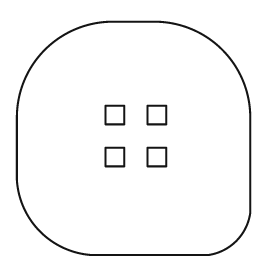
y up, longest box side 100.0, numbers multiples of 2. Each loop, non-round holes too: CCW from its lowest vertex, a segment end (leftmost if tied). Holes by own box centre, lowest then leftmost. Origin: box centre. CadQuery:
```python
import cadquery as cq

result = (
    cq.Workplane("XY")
    .moveTo(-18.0, -50.0)
    .lineTo(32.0, -50.0)
    .threePointArc((44.0, -44.0), (50.0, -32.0))
    .lineTo(50.0, 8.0)
    .threePointArc((38.0, 38.0), (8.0, 50.0))
    .lineTo(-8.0, 50.0)
    .threePointArc((-38.0, 38.0), (-50.0, 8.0))
    .lineTo(-50.0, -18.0)
    .threePointArc((-40.0, -40.0), (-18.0, -50.0))
    .close()
    .moveTo(-12.0, -12.0)
    .lineTo(-4.0, -12.0)
    .lineTo(-4.0, -4.0)
    .lineTo(-12.0, -4.0)
    .close()
    .moveTo(6.0, -12.0)
    .lineTo(14.0, -12.0)
    .lineTo(14.0, -4.0)
    .lineTo(6.0, -4.0)
    .close()
    .moveTo(-12.0, 6.0)
    .lineTo(-4.0, 6.0)
    .lineTo(-4.0, 14.0)
    .lineTo(-12.0, 14.0)
    .close()
    .moveTo(6.0, 6.0)
    .lineTo(14.0, 6.0)
    .lineTo(14.0, 14.0)
    .lineTo(6.0, 14.0)
    .close()
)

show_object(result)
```